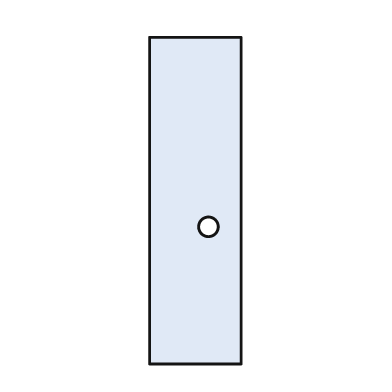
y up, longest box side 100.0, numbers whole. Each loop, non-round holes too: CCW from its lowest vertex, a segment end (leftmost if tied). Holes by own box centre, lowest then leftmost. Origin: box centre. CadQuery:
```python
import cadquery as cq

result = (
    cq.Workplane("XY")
    .moveTo(-14.0, -50.0)
    .lineTo(14.0, -50.0)
    .lineTo(14.0, 50.0)
    .lineTo(-14.0, 50.0)
    .close()
    .moveTo(4.0, -8.0)
    .circle(3.0)
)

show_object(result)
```